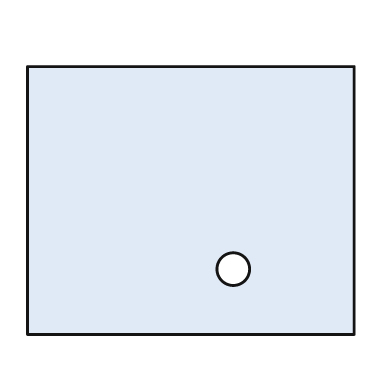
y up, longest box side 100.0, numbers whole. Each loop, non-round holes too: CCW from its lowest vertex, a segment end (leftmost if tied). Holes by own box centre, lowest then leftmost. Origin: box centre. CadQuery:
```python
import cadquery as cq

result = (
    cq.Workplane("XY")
    .moveTo(-50.0, -41.0)
    .lineTo(50.0, -41.0)
    .lineTo(50.0, 41.0)
    .lineTo(-50.0, 41.0)
    .close()
    .moveTo(13.0, -21.0)
    .circle(5.0)
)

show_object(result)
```